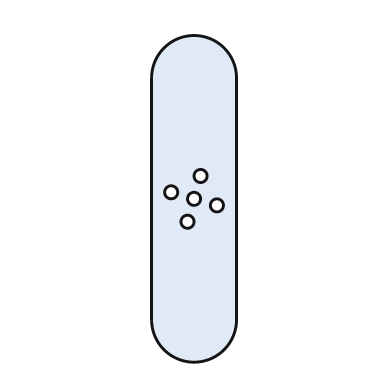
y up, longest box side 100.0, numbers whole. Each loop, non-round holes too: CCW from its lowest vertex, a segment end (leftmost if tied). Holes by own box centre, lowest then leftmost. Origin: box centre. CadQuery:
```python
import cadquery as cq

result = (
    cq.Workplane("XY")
    .moveTo(-13.0, -37.0)
    .threePointArc((0.0, -50.0), (13.0, -37.0))
    .lineTo(13.0, 37.0)
    .threePointArc((0.0, 50.0), (-13.0, 37.0))
    .close()
    .moveTo(-2.0, -7.0)
    .circle(2.0)
    .moveTo(7.0, -2.0)
    .circle(2.0)
    .moveTo(0.0, 0.0)
    .circle(2.0)
    .moveTo(-7.0, 2.0)
    .circle(2.0)
    .moveTo(2.0, 7.0)
    .circle(2.0)
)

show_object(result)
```